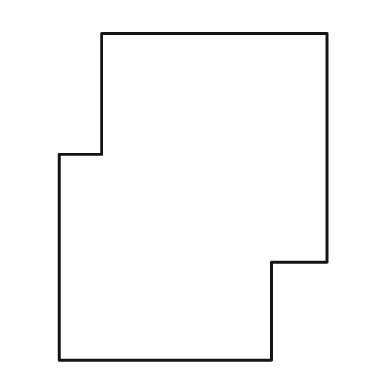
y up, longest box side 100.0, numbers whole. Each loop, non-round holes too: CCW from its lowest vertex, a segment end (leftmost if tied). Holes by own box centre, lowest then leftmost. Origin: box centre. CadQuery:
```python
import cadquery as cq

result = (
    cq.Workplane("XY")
    .moveTo(-41.0, -50.0)
    .lineTo(24.0, -50.0)
    .lineTo(24.0, -20.0)
    .lineTo(41.0, -20.0)
    .lineTo(41.0, 50.0)
    .lineTo(-28.0, 50.0)
    .lineTo(-28.0, 13.0)
    .lineTo(-41.0, 13.0)
    .close()
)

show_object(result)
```